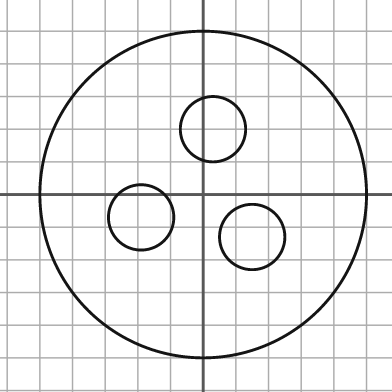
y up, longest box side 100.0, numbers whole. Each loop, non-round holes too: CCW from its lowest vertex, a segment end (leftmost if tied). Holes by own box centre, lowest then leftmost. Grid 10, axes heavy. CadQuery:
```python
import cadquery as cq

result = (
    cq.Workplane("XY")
    .moveTo(0.0, 0.0)
    .circle(50.0)
    .moveTo(15.0, -13.0)
    .circle(10.0)
    .moveTo(-19.0, -7.0)
    .circle(10.0)
    .moveTo(3.0, 20.0)
    .circle(10.0)
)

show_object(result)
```